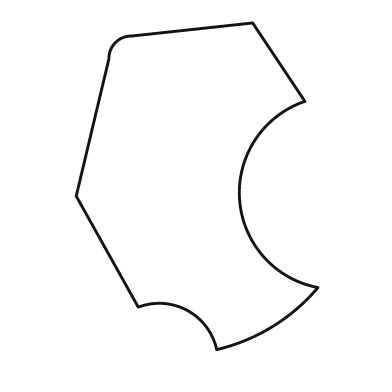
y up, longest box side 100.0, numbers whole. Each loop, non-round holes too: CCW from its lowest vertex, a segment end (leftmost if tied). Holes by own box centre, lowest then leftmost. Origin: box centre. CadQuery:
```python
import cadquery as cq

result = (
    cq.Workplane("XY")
    .moveTo(6.0, -50.0)
    .threePointArc((23.0, -43.0), (37.0, -31.0))
    .threePointArc((13.0, -4.0), (33.0, 26.0))
    .lineTo(17.0, 50.0)
    .lineTo(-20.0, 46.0)
    .threePointArc((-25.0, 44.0), (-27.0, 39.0))
    .lineTo(-37.0, -3.0)
    .lineTo(-18.0, -37.0)
    .threePointArc((-3.0, -38.0), (6.0, -50.0))
    .close()
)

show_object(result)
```